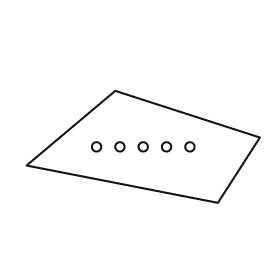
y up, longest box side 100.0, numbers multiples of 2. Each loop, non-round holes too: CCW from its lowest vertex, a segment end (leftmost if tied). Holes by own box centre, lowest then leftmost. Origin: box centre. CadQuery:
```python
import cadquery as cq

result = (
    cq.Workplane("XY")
    .moveTo(32.0, -24.0)
    .lineTo(50.0, 4.0)
    .lineTo(-12.0, 24.0)
    .lineTo(-50.0, -8.0)
    .close()
    .moveTo(-20.0, 0.0)
    .circle(2.0)
    .moveTo(-10.0, 0.0)
    .circle(2.0)
    .moveTo(0.0, 0.0)
    .circle(2.0)
    .moveTo(10.0, 0.0)
    .circle(2.0)
    .moveTo(20.0, 0.0)
    .circle(2.0)
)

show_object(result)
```